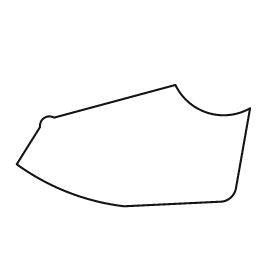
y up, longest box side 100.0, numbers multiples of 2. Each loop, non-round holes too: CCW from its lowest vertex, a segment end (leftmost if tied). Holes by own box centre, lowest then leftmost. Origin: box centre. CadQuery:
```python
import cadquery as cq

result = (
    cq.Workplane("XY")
    .moveTo(-4.0, -26.0)
    .lineTo(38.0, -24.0)
    .threePointArc((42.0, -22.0), (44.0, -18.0))
    .lineTo(50.0, 16.0)
    .threePointArc((32.0, 14.0), (18.0, 26.0))
    .lineTo(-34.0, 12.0)
    .threePointArc((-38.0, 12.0), (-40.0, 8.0))
    .lineTo(-50.0, -8.0)
    .threePointArc((-28.0, -20.0), (-4.0, -26.0))
    .close()
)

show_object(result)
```